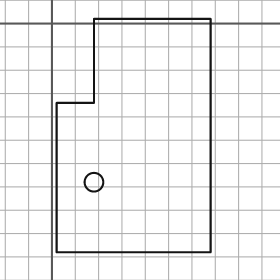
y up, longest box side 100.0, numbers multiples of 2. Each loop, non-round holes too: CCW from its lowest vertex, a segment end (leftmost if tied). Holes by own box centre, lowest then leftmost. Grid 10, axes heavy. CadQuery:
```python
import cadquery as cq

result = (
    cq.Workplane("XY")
    .moveTo(2.0, -98.0)
    .lineTo(68.0, -98.0)
    .lineTo(68.0, 2.0)
    .lineTo(18.0, 2.0)
    .lineTo(18.0, -34.0)
    .lineTo(2.0, -34.0)
    .close()
    .moveTo(18.0, -68.0)
    .circle(4.0)
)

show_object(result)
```